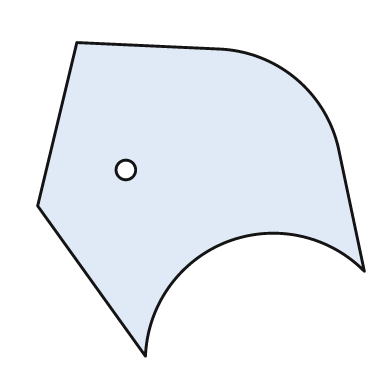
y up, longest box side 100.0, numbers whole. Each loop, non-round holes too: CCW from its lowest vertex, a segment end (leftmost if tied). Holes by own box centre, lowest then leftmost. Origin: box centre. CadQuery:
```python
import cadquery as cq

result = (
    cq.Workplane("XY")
    .moveTo(-17.0, -48.0)
    .threePointArc((8.0, -13.0), (50.0, -22.0))
    .lineTo(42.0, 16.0)
    .threePointArc((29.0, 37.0), (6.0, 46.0))
    .lineTo(-38.0, 48.0)
    .lineTo(-50.0, -2.0)
    .close()
    .moveTo(-23.0, 9.0)
    .circle(3.0)
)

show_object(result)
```